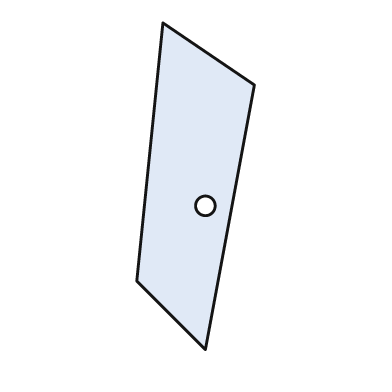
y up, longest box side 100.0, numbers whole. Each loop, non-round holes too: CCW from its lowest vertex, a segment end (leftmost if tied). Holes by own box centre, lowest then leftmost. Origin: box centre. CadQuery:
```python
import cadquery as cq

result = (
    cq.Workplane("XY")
    .moveTo(3.0, -50.0)
    .lineTo(18.0, 31.0)
    .lineTo(-10.0, 50.0)
    .lineTo(-18.0, -29.0)
    .close()
    .moveTo(3.0, -6.0)
    .circle(3.0)
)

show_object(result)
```